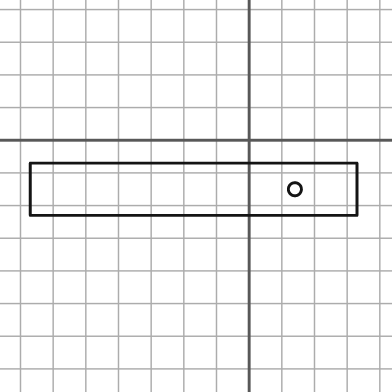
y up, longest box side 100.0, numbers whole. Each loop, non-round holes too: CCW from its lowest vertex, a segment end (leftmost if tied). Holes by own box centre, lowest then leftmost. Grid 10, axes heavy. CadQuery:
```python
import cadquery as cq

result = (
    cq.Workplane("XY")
    .moveTo(-67.0, -23.0)
    .lineTo(33.0, -23.0)
    .lineTo(33.0, -7.0)
    .lineTo(-67.0, -7.0)
    .close()
    .moveTo(14.0, -15.0)
    .circle(2.0)
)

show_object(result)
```